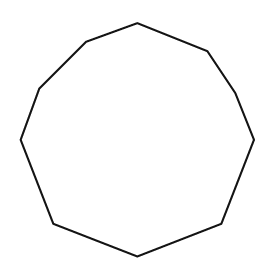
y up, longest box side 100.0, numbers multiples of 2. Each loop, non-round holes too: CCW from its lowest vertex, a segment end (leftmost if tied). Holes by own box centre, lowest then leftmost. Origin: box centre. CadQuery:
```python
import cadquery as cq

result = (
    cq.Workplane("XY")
    .moveTo(0.0, -50.0)
    .lineTo(36.0, -36.0)
    .lineTo(50.0, 0.0)
    .lineTo(42.0, 20.0)
    .lineTo(30.0, 38.0)
    .lineTo(0.0, 50.0)
    .lineTo(-22.0, 42.0)
    .lineTo(-42.0, 22.0)
    .lineTo(-50.0, 0.0)
    .lineTo(-36.0, -36.0)
    .close()
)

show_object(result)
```